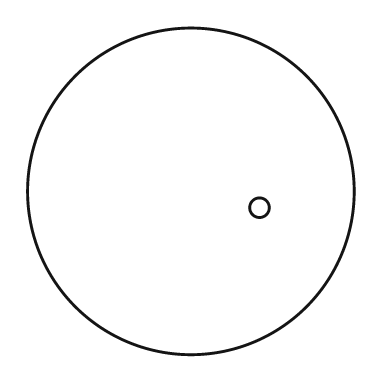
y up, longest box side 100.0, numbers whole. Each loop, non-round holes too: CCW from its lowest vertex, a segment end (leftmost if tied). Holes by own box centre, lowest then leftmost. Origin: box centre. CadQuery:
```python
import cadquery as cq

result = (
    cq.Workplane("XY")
    .moveTo(0.0, 0.0)
    .circle(50.0)
    .moveTo(21.0, -5.0)
    .circle(3.0)
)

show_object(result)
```